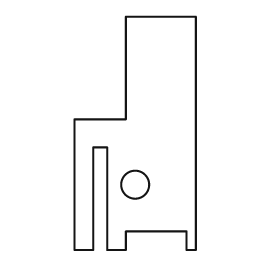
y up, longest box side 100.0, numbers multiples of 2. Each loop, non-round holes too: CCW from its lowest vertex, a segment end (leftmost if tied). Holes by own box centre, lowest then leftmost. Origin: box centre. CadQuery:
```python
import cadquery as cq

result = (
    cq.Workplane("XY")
    .moveTo(-26.0, -50.0)
    .lineTo(-18.0, -50.0)
    .lineTo(-18.0, -6.0)
    .lineTo(-12.0, -6.0)
    .lineTo(-12.0, -50.0)
    .lineTo(-4.0, -50.0)
    .lineTo(-4.0, -42.0)
    .lineTo(22.0, -42.0)
    .lineTo(22.0, -50.0)
    .lineTo(26.0, -50.0)
    .lineTo(26.0, 50.0)
    .lineTo(-4.0, 50.0)
    .lineTo(-4.0, 6.0)
    .lineTo(-26.0, 6.0)
    .close()
    .moveTo(0.0, -22.0)
    .circle(6.0)
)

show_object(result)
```